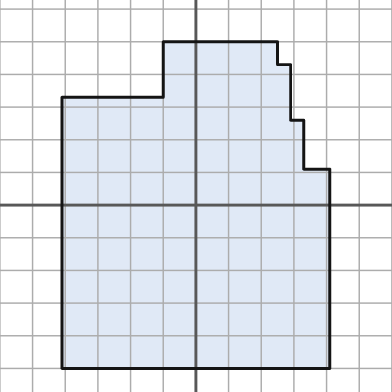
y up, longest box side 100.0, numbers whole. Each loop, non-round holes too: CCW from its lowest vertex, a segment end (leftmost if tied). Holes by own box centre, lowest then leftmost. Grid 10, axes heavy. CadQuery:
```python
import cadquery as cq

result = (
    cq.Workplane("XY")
    .moveTo(-41.0, -50.0)
    .lineTo(41.0, -50.0)
    .lineTo(41.0, 11.0)
    .lineTo(33.0, 11.0)
    .lineTo(33.0, 26.0)
    .lineTo(29.0, 26.0)
    .lineTo(29.0, 43.0)
    .lineTo(25.0, 43.0)
    .lineTo(25.0, 50.0)
    .lineTo(-10.0, 50.0)
    .lineTo(-10.0, 33.0)
    .lineTo(-41.0, 33.0)
    .close()
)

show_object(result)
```